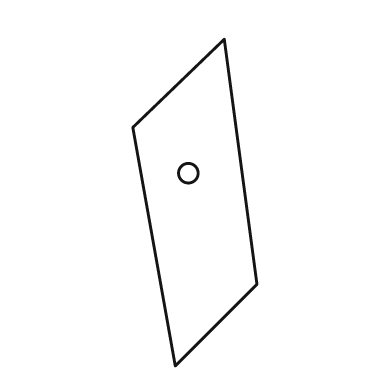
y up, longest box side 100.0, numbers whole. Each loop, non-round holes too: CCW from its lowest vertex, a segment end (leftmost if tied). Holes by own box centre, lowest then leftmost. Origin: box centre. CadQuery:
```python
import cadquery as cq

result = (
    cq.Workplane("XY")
    .moveTo(-6.0, -50.0)
    .lineTo(19.0, -25.0)
    .lineTo(9.0, 50.0)
    .lineTo(-19.0, 23.0)
    .close()
    .moveTo(-2.0, 9.0)
    .circle(3.0)
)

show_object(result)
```